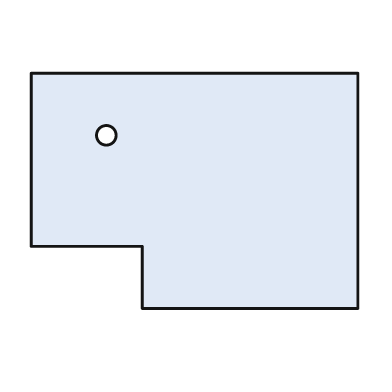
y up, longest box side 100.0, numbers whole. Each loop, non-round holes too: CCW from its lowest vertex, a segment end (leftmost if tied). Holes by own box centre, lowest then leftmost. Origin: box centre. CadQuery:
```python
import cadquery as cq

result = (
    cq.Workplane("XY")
    .moveTo(-16.0, -36.0)
    .lineTo(50.0, -36.0)
    .lineTo(50.0, 36.0)
    .lineTo(-50.0, 36.0)
    .lineTo(-50.0, -17.0)
    .lineTo(-16.0, -17.0)
    .close()
    .moveTo(-27.0, 17.0)
    .circle(3.0)
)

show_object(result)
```